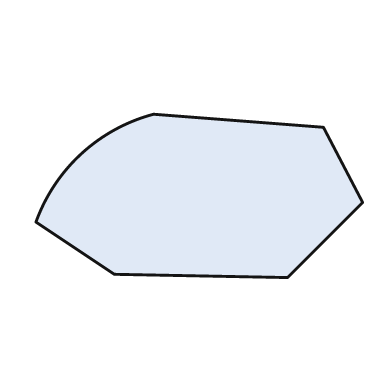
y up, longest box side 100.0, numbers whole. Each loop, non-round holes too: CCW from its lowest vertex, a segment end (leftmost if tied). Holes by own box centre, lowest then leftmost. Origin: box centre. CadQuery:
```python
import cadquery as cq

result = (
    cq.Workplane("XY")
    .moveTo(27.0, -25.0)
    .lineTo(50.0, -2.0)
    .lineTo(38.0, 21.0)
    .lineTo(-14.0, 25.0)
    .threePointArc((-36.0, 13.0), (-50.0, -8.0))
    .lineTo(-26.0, -24.0)
    .close()
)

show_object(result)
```